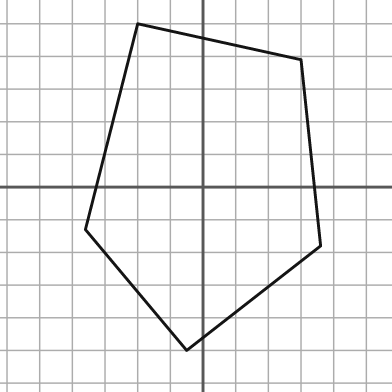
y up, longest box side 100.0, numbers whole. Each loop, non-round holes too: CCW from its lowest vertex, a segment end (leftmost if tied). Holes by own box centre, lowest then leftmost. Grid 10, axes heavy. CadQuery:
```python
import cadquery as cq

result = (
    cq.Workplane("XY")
    .moveTo(-5.0, -50.0)
    .lineTo(36.0, -18.0)
    .lineTo(30.0, 39.0)
    .lineTo(-20.0, 50.0)
    .lineTo(-36.0, -13.0)
    .close()
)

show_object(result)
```